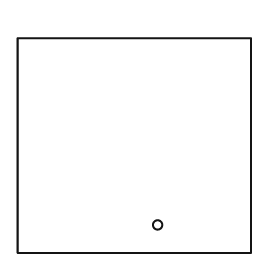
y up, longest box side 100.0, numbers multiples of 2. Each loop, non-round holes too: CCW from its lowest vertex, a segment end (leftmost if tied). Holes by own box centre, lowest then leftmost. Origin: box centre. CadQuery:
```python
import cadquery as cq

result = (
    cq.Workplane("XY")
    .moveTo(-50.0, -46.0)
    .lineTo(50.0, -46.0)
    .lineTo(50.0, 46.0)
    .lineTo(-50.0, 46.0)
    .close()
    .moveTo(10.0, -34.0)
    .circle(2.0)
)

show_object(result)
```